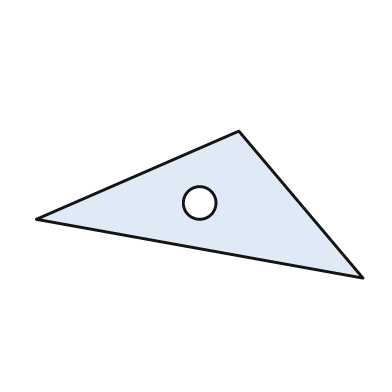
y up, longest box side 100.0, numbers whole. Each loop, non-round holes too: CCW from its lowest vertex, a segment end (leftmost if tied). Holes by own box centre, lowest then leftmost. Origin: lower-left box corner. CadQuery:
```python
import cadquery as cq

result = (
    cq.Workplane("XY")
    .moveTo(100.0, 0.0)
    .lineTo(62.0, 45.0)
    .lineTo(0.0, 18.0)
    .close()
    .moveTo(50.0, 23.0)
    .circle(5.0)
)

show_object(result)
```